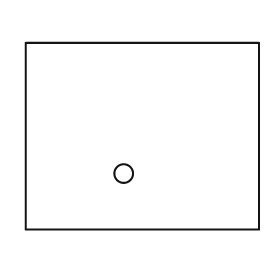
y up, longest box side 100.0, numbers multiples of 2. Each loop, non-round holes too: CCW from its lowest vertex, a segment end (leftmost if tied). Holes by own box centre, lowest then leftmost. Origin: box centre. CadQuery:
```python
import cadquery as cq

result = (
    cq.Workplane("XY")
    .moveTo(-50.0, -40.0)
    .lineTo(50.0, -40.0)
    .lineTo(50.0, 40.0)
    .lineTo(-50.0, 40.0)
    .close()
    .moveTo(-8.0, -16.0)
    .circle(4.0)
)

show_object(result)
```